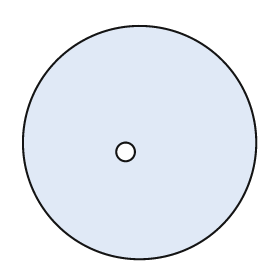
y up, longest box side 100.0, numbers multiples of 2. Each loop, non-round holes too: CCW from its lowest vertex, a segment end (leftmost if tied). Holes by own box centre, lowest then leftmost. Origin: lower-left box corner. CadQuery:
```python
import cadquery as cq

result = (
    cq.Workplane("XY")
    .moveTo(50.0, 50.0)
    .circle(50.0)
    .moveTo(44.0, 46.0)
    .circle(4.0)
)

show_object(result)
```